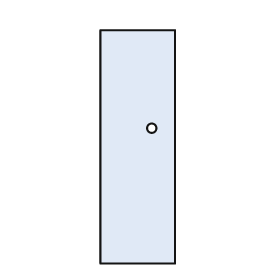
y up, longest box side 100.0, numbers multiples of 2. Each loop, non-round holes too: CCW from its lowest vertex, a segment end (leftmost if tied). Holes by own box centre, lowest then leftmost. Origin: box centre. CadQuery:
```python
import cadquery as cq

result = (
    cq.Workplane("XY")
    .moveTo(-16.0, -50.0)
    .lineTo(16.0, -50.0)
    .lineTo(16.0, 50.0)
    .lineTo(-16.0, 50.0)
    .close()
    .moveTo(6.0, 8.0)
    .circle(2.0)
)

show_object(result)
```